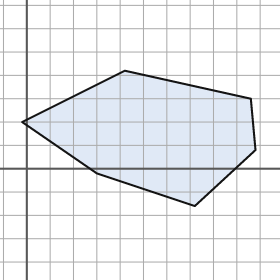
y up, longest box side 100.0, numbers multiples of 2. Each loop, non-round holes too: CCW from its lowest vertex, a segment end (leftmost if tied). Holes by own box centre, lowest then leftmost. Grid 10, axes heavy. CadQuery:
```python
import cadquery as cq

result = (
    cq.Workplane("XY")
    .moveTo(72.0, -16.0)
    .lineTo(98.0, 8.0)
    .lineTo(96.0, 30.0)
    .lineTo(42.0, 42.0)
    .lineTo(-2.0, 20.0)
    .lineTo(30.0, -2.0)
    .close()
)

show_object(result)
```